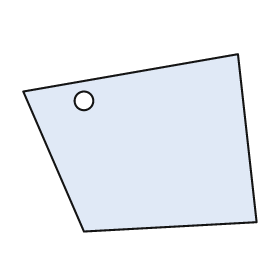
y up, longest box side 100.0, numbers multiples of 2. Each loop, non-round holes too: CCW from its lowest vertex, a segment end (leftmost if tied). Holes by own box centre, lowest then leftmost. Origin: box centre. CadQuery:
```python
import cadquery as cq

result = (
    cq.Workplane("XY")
    .moveTo(-24.0, -38.0)
    .lineTo(50.0, -34.0)
    .lineTo(42.0, 38.0)
    .lineTo(-50.0, 22.0)
    .close()
    .moveTo(-24.0, 18.0)
    .circle(4.0)
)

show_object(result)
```